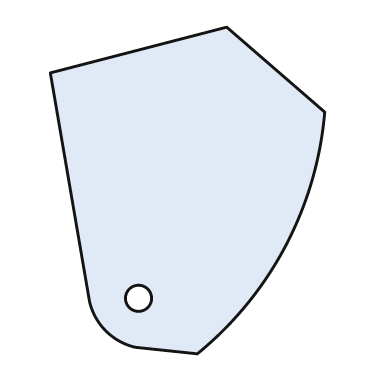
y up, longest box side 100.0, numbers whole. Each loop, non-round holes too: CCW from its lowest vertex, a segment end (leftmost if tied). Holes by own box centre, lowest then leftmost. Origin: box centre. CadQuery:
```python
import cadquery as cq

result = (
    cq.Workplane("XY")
    .moveTo(3.0, -50.0)
    .threePointArc((30.0, -17.0), (42.0, 24.0))
    .lineTo(12.0, 50.0)
    .lineTo(-42.0, 36.0)
    .lineTo(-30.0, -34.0)
    .threePointArc((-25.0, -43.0), (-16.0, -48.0))
    .close()
    .moveTo(-15.0, -33.0)
    .circle(4.0)
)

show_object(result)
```